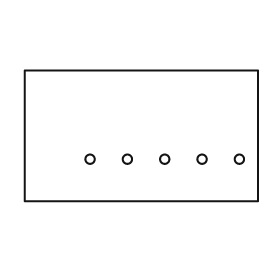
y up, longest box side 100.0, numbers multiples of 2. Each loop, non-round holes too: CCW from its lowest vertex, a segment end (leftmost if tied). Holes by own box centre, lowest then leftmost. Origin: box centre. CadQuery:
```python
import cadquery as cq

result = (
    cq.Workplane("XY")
    .moveTo(-50.0, -28.0)
    .lineTo(50.0, -28.0)
    .lineTo(50.0, 28.0)
    .lineTo(-50.0, 28.0)
    .close()
    .moveTo(-22.0, -10.0)
    .circle(2.0)
    .moveTo(-6.0, -10.0)
    .circle(2.0)
    .moveTo(10.0, -10.0)
    .circle(2.0)
    .moveTo(26.0, -10.0)
    .circle(2.0)
    .moveTo(42.0, -10.0)
    .circle(2.0)
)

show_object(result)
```